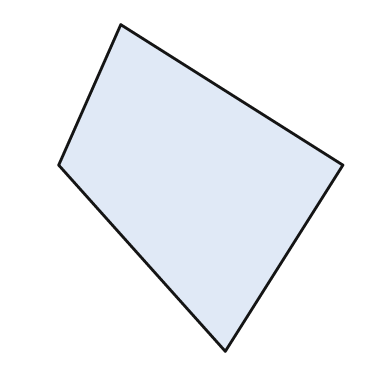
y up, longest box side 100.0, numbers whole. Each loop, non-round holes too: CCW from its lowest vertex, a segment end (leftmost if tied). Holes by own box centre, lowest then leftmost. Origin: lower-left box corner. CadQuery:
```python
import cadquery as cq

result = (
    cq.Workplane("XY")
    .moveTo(51.0, 0.0)
    .lineTo(87.0, 57.0)
    .lineTo(19.0, 100.0)
    .lineTo(0.0, 57.0)
    .close()
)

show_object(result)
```